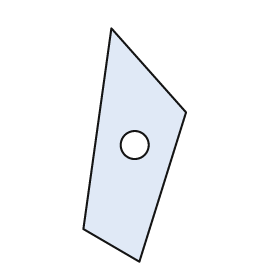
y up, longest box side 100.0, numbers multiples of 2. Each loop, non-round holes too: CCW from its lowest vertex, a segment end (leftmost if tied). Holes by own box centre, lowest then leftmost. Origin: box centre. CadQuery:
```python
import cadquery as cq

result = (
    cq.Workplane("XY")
    .moveTo(2.0, -50.0)
    .lineTo(22.0, 14.0)
    .lineTo(-10.0, 50.0)
    .lineTo(-22.0, -36.0)
    .close()
    .moveTo(0.0, 0.0)
    .circle(6.0)
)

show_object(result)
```